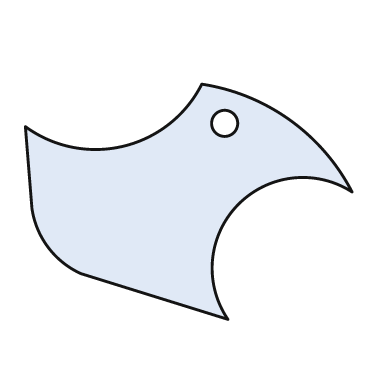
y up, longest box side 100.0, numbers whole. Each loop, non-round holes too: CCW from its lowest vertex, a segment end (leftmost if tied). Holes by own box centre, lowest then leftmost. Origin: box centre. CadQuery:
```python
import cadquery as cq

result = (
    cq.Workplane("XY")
    .moveTo(12.0, -36.0)
    .threePointArc((15.0, -1.0), (50.0, 3.0))
    .threePointArc((31.0, 25.0), (4.0, 36.0))
    .threePointArc((-20.0, 17.0), (-50.0, 23.0))
    .lineTo(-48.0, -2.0)
    .threePointArc((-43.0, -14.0), (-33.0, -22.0))
    .close()
    .moveTo(11.0, 24.0)
    .circle(4.0)
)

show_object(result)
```